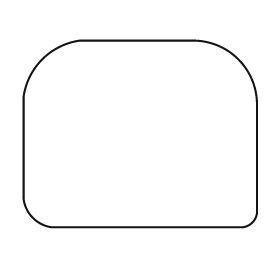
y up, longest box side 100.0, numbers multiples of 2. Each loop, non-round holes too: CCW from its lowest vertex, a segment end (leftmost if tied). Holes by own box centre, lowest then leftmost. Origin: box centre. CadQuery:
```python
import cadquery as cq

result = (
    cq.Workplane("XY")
    .moveTo(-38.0, -40.0)
    .lineTo(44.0, -40.0)
    .threePointArc((48.0, -38.0), (50.0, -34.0))
    .lineTo(50.0, 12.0)
    .threePointArc((42.0, 32.0), (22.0, 40.0))
    .lineTo(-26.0, 40.0)
    .threePointArc((-42.0, 32.0), (-50.0, 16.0))
    .lineTo(-50.0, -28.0)
    .threePointArc((-46.0, -36.0), (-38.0, -40.0))
    .close()
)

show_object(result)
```